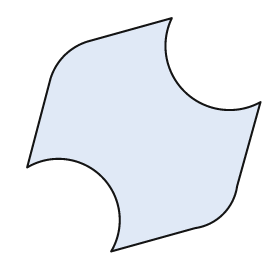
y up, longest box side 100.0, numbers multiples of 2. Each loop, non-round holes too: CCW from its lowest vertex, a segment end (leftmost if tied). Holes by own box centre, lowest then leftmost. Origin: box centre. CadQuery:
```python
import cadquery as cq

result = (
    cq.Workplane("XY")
    .moveTo(-14.0, -50.0)
    .lineTo(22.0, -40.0)
    .threePointArc((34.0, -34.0), (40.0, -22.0))
    .lineTo(50.0, 14.0)
    .threePointArc((18.0, 18.0), (12.0, 50.0))
    .lineTo(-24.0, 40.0)
    .threePointArc((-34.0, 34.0), (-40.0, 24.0))
    .lineTo(-50.0, -14.0)
    .threePointArc((-18.0, -18.0), (-14.0, -50.0))
    .close()
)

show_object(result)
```